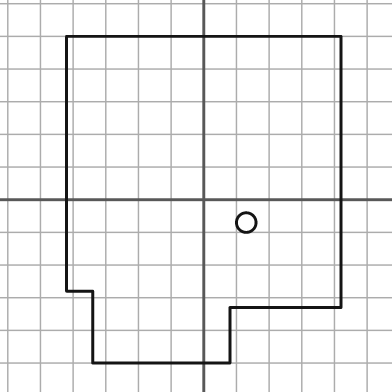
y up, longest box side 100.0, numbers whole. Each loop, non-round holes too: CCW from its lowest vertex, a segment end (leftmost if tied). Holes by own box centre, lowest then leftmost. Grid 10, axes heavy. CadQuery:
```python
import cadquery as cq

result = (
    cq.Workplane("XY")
    .moveTo(-34.0, -50.0)
    .lineTo(8.0, -50.0)
    .lineTo(8.0, -33.0)
    .lineTo(42.0, -33.0)
    .lineTo(42.0, 50.0)
    .lineTo(-42.0, 50.0)
    .lineTo(-42.0, -28.0)
    .lineTo(-34.0, -28.0)
    .close()
    .moveTo(13.0, -7.0)
    .circle(3.0)
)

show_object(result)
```